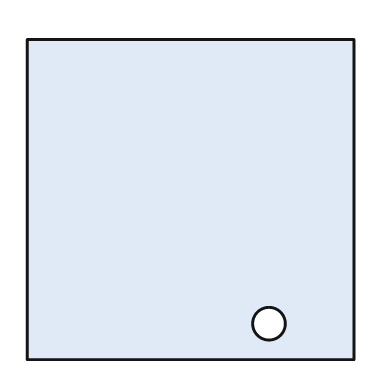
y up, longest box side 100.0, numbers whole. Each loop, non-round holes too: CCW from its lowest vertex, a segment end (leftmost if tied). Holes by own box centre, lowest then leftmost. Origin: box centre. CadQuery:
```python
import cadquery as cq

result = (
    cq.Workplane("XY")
    .moveTo(-50.0, -49.0)
    .lineTo(50.0, -49.0)
    .lineTo(50.0, 49.0)
    .lineTo(-50.0, 49.0)
    .close()
    .moveTo(24.0, -38.0)
    .circle(5.0)
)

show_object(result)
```